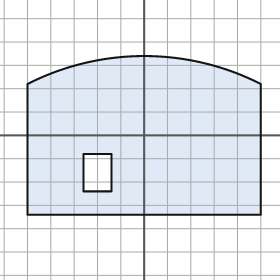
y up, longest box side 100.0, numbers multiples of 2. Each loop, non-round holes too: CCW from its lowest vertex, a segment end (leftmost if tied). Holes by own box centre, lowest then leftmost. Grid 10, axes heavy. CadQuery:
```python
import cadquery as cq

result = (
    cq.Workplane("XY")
    .moveTo(-50.0, -34.0)
    .lineTo(50.0, -34.0)
    .lineTo(50.0, 22.0)
    .threePointArc((0.0, 34.0), (-50.0, 22.0))
    .close()
    .moveTo(-26.0, -24.0)
    .lineTo(-14.0, -24.0)
    .lineTo(-14.0, -8.0)
    .lineTo(-26.0, -8.0)
    .close()
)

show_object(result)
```